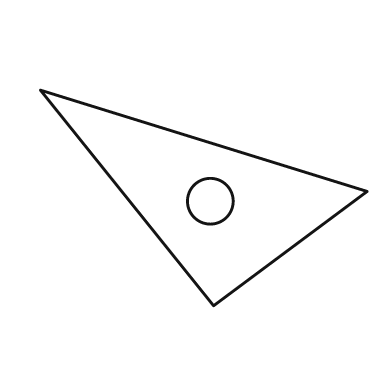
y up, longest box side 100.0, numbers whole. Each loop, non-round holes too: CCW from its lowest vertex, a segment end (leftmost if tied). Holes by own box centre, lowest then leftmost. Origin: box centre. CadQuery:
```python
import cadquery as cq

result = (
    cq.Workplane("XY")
    .moveTo(3.0, -33.0)
    .lineTo(50.0, 2.0)
    .lineTo(-50.0, 33.0)
    .close()
    .moveTo(2.0, -1.0)
    .circle(7.0)
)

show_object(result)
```